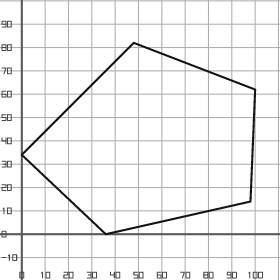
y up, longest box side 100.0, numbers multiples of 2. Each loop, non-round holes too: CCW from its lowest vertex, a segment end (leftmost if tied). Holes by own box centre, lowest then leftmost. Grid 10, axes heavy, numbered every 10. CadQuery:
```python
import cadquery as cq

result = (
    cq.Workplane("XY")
    .moveTo(36.0, 0.0)
    .lineTo(98.0, 14.0)
    .lineTo(100.0, 62.0)
    .lineTo(48.0, 82.0)
    .lineTo(0.0, 34.0)
    .close()
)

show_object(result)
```